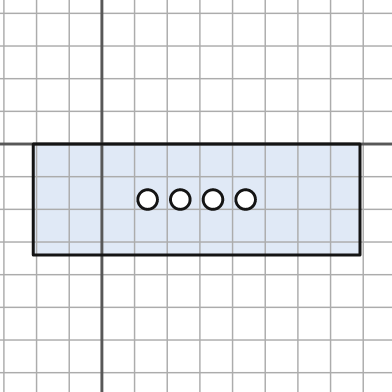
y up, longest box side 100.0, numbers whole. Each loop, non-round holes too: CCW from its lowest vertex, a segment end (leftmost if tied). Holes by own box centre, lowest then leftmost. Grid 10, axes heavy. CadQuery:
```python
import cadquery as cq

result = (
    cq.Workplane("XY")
    .moveTo(-21.0, -34.0)
    .lineTo(79.0, -34.0)
    .lineTo(79.0, 0.0)
    .lineTo(-21.0, 0.0)
    .close()
    .moveTo(14.0, -17.0)
    .circle(3.0)
    .moveTo(24.0, -17.0)
    .circle(3.0)
    .moveTo(34.0, -17.0)
    .circle(3.0)
    .moveTo(44.0, -17.0)
    .circle(3.0)
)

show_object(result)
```